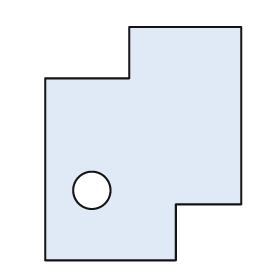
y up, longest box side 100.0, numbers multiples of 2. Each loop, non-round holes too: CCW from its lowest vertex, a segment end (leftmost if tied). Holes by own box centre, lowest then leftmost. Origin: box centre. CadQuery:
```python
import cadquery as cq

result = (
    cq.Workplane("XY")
    .moveTo(-42.0, -50.0)
    .lineTo(14.0, -50.0)
    .lineTo(14.0, -26.0)
    .lineTo(42.0, -26.0)
    .lineTo(42.0, 50.0)
    .lineTo(-6.0, 50.0)
    .lineTo(-6.0, 28.0)
    .lineTo(-42.0, 28.0)
    .close()
    .moveTo(-22.0, -20.0)
    .circle(8.0)
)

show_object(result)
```